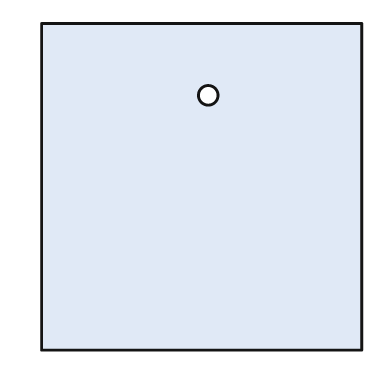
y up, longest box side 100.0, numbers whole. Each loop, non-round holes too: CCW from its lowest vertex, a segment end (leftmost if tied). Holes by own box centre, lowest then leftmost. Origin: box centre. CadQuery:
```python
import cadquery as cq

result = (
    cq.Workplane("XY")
    .moveTo(-49.0, -50.0)
    .lineTo(49.0, -50.0)
    .lineTo(49.0, 50.0)
    .lineTo(-49.0, 50.0)
    .close()
    .moveTo(2.0, 28.0)
    .circle(3.0)
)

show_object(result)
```